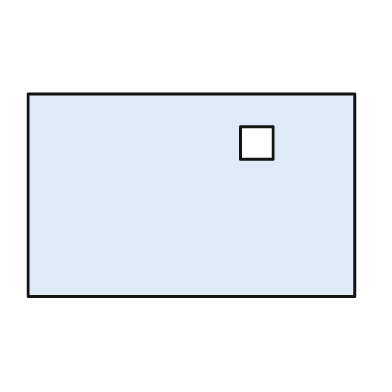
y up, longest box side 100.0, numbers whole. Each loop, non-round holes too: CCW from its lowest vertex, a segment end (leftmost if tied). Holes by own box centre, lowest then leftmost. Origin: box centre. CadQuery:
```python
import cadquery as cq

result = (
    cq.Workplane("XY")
    .moveTo(-50.0, -31.0)
    .lineTo(50.0, -31.0)
    .lineTo(50.0, 31.0)
    .lineTo(-50.0, 31.0)
    .close()
    .moveTo(15.0, 11.0)
    .lineTo(25.0, 11.0)
    .lineTo(25.0, 21.0)
    .lineTo(15.0, 21.0)
    .close()
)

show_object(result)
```